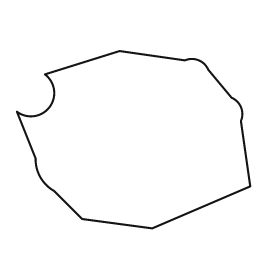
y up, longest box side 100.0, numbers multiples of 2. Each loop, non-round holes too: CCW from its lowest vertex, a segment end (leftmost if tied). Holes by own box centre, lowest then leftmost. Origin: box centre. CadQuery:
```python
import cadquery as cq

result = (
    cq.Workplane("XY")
    .moveTo(8.0, -38.0)
    .lineTo(50.0, -20.0)
    .lineTo(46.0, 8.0)
    .threePointArc((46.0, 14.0), (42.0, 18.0))
    .lineTo(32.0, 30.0)
    .threePointArc((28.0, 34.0), (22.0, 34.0))
    .lineTo(-6.0, 38.0)
    .lineTo(-38.0, 28.0)
    .threePointArc((-36.0, 14.0), (-50.0, 12.0))
    .lineTo(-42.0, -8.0)
    .threePointArc((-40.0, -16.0), (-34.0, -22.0))
    .lineTo(-22.0, -34.0)
    .close()
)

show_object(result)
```